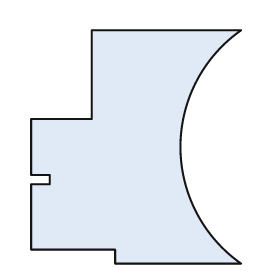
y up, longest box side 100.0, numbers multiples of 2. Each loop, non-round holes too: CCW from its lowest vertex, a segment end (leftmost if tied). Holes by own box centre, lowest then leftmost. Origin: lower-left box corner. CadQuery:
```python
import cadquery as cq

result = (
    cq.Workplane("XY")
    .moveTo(36.0, 0.0)
    .lineTo(90.0, 0.0)
    .threePointArc((64.0, 50.0), (90.0, 100.0))
    .lineTo(26.0, 100.0)
    .lineTo(26.0, 62.0)
    .lineTo(0.0, 62.0)
    .lineTo(0.0, 38.0)
    .lineTo(8.0, 38.0)
    .lineTo(8.0, 34.0)
    .lineTo(0.0, 34.0)
    .lineTo(0.0, 6.0)
    .lineTo(36.0, 6.0)
    .close()
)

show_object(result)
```